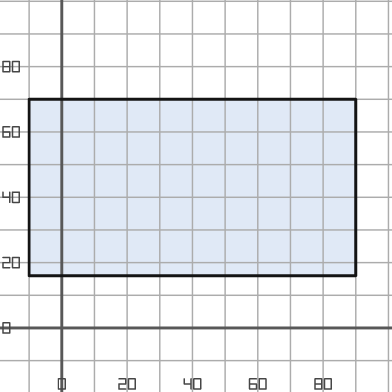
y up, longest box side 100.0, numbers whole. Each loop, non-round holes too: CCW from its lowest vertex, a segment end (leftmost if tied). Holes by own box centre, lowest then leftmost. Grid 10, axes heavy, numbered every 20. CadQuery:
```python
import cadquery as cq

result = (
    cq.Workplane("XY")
    .moveTo(-10.0, 16.0)
    .lineTo(90.0, 16.0)
    .lineTo(90.0, 70.0)
    .lineTo(-10.0, 70.0)
    .close()
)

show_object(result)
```